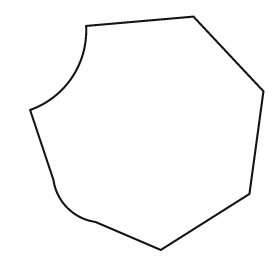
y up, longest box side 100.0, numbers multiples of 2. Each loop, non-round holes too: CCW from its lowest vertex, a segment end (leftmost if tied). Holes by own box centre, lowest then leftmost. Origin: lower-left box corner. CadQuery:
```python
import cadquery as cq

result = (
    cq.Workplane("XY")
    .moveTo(56.0, 0.0)
    .lineTo(94.0, 24.0)
    .lineTo(100.0, 68.0)
    .lineTo(70.0, 100.0)
    .lineTo(24.0, 96.0)
    .threePointArc((18.0, 74.0), (0.0, 60.0))
    .lineTo(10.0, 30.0)
    .threePointArc((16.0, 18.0), (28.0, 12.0))
    .close()
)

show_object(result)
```